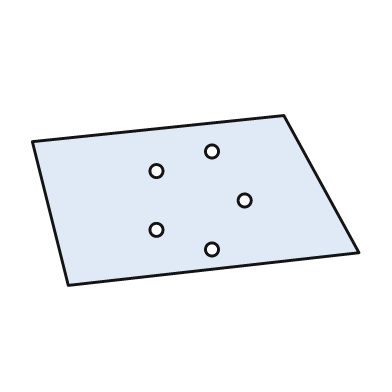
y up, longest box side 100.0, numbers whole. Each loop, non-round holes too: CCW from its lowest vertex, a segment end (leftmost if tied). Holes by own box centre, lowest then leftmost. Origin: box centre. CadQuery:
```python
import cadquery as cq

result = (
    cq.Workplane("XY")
    .moveTo(-39.0, -26.0)
    .lineTo(50.0, -16.0)
    .lineTo(27.0, 26.0)
    .lineTo(-50.0, 18.0)
    .close()
    .moveTo(5.0, -15.0)
    .circle(2.0)
    .moveTo(-12.0, -9.0)
    .circle(2.0)
    .moveTo(15.0, 0.0)
    .circle(2.0)
    .moveTo(-12.0, 9.0)
    .circle(2.0)
    .moveTo(5.0, 15.0)
    .circle(2.0)
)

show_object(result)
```